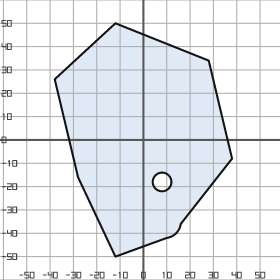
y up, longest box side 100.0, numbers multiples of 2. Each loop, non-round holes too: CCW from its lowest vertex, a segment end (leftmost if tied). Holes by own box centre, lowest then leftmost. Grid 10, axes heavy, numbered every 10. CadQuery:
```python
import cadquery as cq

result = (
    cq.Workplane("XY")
    .moveTo(-12.0, -50.0)
    .lineTo(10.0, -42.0)
    .threePointArc((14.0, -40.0), (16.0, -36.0))
    .lineTo(38.0, -8.0)
    .lineTo(28.0, 34.0)
    .lineTo(-12.0, 50.0)
    .lineTo(-38.0, 26.0)
    .lineTo(-28.0, -16.0)
    .close()
    .moveTo(8.0, -18.0)
    .circle(4.0)
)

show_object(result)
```